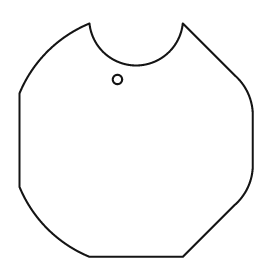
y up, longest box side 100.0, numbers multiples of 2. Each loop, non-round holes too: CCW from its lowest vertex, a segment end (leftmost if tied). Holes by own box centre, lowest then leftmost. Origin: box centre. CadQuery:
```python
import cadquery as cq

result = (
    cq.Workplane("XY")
    .moveTo(-20.0, -50.0)
    .lineTo(20.0, -50.0)
    .lineTo(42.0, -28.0)
    .threePointArc((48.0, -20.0), (50.0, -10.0))
    .lineTo(50.0, 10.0)
    .threePointArc((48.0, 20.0), (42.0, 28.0))
    .lineTo(20.0, 50.0)
    .threePointArc((0.0, 32.0), (-20.0, 50.0))
    .threePointArc((-38.0, 38.0), (-50.0, 20.0))
    .lineTo(-50.0, -20.0)
    .threePointArc((-38.0, -38.0), (-20.0, -50.0))
    .close()
    .moveTo(-8.0, 26.0)
    .circle(2.0)
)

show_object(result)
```